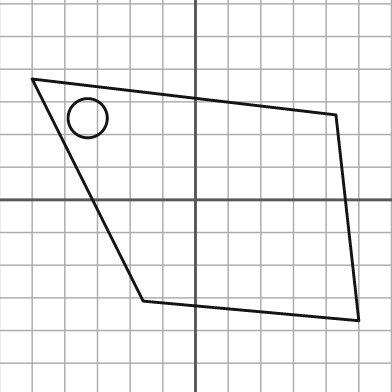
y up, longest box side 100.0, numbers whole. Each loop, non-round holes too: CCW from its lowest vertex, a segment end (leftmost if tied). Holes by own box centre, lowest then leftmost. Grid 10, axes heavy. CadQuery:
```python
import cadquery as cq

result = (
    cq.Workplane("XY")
    .moveTo(50.0, -37.0)
    .lineTo(43.0, 26.0)
    .lineTo(-50.0, 37.0)
    .lineTo(-16.0, -31.0)
    .close()
    .moveTo(-33.0, 25.0)
    .circle(6.0)
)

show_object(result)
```